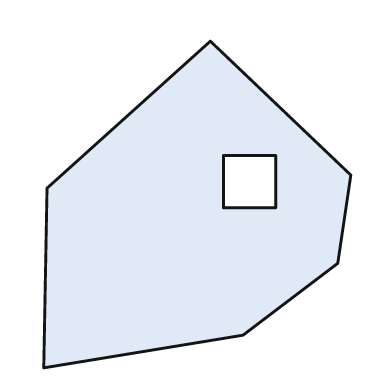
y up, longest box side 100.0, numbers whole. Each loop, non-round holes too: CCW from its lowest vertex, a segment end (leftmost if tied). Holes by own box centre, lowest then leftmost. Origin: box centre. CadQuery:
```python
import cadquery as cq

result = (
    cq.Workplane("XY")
    .moveTo(-47.0, -50.0)
    .lineTo(14.0, -40.0)
    .lineTo(43.0, -18.0)
    .lineTo(47.0, 9.0)
    .lineTo(4.0, 50.0)
    .lineTo(-46.0, 5.0)
    .close()
    .moveTo(8.0, -1.0)
    .lineTo(24.0, -1.0)
    .lineTo(24.0, 15.0)
    .lineTo(8.0, 15.0)
    .close()
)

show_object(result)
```